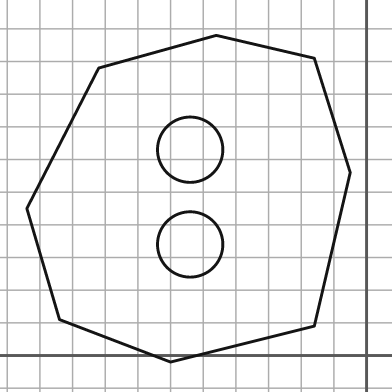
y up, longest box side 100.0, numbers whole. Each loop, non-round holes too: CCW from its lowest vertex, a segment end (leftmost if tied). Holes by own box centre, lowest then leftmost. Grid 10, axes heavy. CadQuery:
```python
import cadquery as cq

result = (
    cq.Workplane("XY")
    .moveTo(-60.0, -2.0)
    .lineTo(-16.0, 9.0)
    .lineTo(-5.0, 56.0)
    .lineTo(-16.0, 91.0)
    .lineTo(-46.0, 98.0)
    .lineTo(-82.0, 88.0)
    .lineTo(-104.0, 45.0)
    .lineTo(-94.0, 11.0)
    .close()
    .moveTo(-54.0, 34.0)
    .circle(10.0)
    .moveTo(-54.0, 63.0)
    .circle(10.0)
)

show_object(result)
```